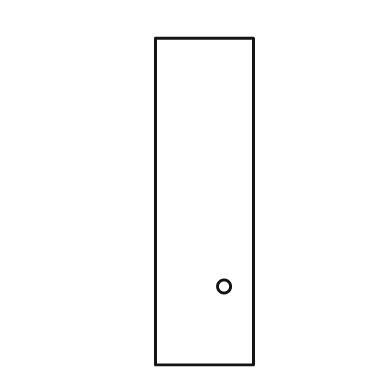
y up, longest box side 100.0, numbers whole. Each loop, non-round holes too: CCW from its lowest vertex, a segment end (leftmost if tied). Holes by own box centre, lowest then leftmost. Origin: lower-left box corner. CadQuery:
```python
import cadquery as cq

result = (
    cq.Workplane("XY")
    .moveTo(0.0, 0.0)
    .lineTo(30.0, 0.0)
    .lineTo(30.0, 100.0)
    .lineTo(0.0, 100.0)
    .close()
    .moveTo(21.0, 24.0)
    .circle(2.0)
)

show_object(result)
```